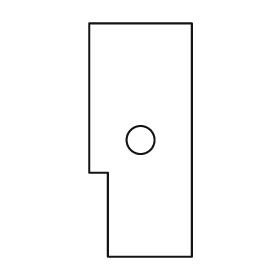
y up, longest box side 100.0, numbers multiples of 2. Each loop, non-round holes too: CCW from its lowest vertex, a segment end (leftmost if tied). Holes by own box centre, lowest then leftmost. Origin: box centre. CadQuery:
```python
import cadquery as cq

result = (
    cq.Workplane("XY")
    .moveTo(-14.0, -50.0)
    .lineTo(22.0, -50.0)
    .lineTo(22.0, 50.0)
    .lineTo(-22.0, 50.0)
    .lineTo(-22.0, -14.0)
    .lineTo(-14.0, -14.0)
    .close()
    .moveTo(0.0, 0.0)
    .circle(6.0)
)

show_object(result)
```